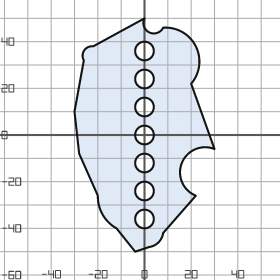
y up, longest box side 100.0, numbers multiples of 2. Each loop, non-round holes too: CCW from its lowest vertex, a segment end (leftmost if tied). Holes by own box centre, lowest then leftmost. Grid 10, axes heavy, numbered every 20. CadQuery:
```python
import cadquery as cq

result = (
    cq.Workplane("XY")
    .moveTo(-4.0, -50.0)
    .lineTo(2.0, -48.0)
    .threePointArc((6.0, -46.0), (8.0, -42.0))
    .lineTo(22.0, -26.0)
    .threePointArc((16.0, -12.0), (30.0, -6.0))
    .lineTo(20.0, 22.0)
    .threePointArc((22.0, 38.0), (8.0, 46.0))
    .threePointArc((2.0, 44.0), (0.0, 50.0))
    .lineTo(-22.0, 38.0)
    .threePointArc((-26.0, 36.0), (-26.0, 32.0))
    .lineTo(-30.0, 10.0)
    .lineTo(-28.0, -8.0)
    .lineTo(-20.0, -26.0)
    .threePointArc((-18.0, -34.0), (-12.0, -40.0))
    .close()
    .moveTo(0.0, -36.0)
    .circle(4.0)
    .moveTo(0.0, -24.0)
    .circle(4.0)
    .moveTo(0.0, -12.0)
    .circle(4.0)
    .moveTo(0.0, 0.0)
    .circle(4.0)
    .moveTo(0.0, 12.0)
    .circle(4.0)
    .moveTo(0.0, 24.0)
    .circle(4.0)
    .moveTo(0.0, 36.0)
    .circle(4.0)
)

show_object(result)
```